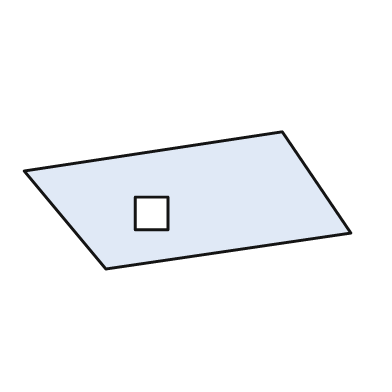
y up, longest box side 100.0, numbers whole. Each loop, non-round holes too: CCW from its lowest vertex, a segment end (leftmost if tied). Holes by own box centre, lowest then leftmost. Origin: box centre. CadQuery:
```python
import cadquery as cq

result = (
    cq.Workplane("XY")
    .moveTo(-25.0, -21.0)
    .lineTo(50.0, -10.0)
    .lineTo(29.0, 21.0)
    .lineTo(-50.0, 9.0)
    .close()
    .moveTo(-16.0, -9.0)
    .lineTo(-6.0, -9.0)
    .lineTo(-6.0, 1.0)
    .lineTo(-16.0, 1.0)
    .close()
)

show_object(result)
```